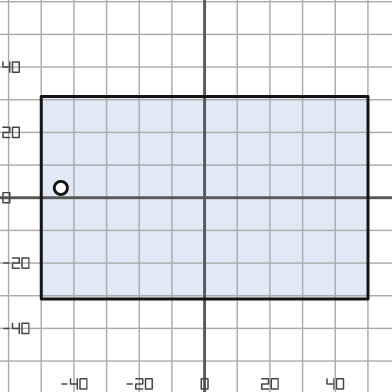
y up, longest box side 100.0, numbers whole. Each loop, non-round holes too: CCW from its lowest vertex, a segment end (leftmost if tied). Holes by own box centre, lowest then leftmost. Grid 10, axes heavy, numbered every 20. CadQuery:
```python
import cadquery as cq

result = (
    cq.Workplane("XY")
    .moveTo(-50.0, -31.0)
    .lineTo(50.0, -31.0)
    .lineTo(50.0, 31.0)
    .lineTo(-50.0, 31.0)
    .close()
    .moveTo(-44.0, 3.0)
    .circle(2.0)
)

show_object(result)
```